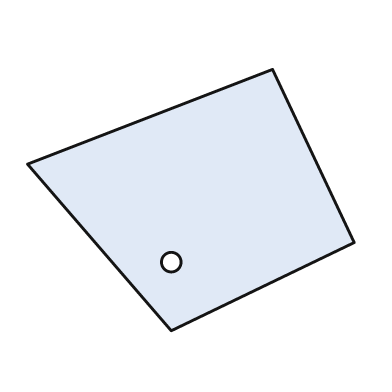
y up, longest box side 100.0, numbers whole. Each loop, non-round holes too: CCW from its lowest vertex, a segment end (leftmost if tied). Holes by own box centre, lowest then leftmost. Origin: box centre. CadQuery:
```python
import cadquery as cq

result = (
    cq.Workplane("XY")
    .moveTo(-6.0, -40.0)
    .lineTo(50.0, -13.0)
    .lineTo(25.0, 40.0)
    .lineTo(-50.0, 11.0)
    .close()
    .moveTo(-6.0, -19.0)
    .circle(3.0)
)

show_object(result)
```